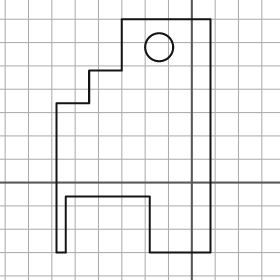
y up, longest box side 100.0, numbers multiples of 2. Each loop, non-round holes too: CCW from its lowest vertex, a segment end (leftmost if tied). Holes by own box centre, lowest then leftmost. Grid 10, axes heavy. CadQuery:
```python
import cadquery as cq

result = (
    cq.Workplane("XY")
    .moveTo(-58.0, -30.0)
    .lineTo(-54.0, -30.0)
    .lineTo(-54.0, -6.0)
    .lineTo(-18.0, -6.0)
    .lineTo(-18.0, -30.0)
    .lineTo(8.0, -30.0)
    .lineTo(8.0, 70.0)
    .lineTo(-30.0, 70.0)
    .lineTo(-30.0, 48.0)
    .lineTo(-44.0, 48.0)
    .lineTo(-44.0, 34.0)
    .lineTo(-58.0, 34.0)
    .close()
    .moveTo(-14.0, 58.0)
    .circle(6.0)
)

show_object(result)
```